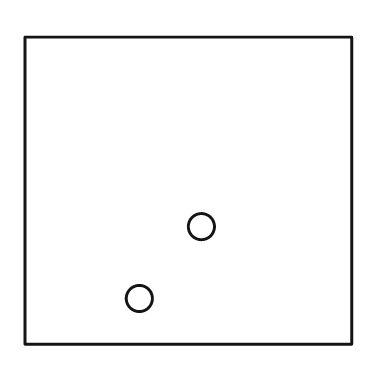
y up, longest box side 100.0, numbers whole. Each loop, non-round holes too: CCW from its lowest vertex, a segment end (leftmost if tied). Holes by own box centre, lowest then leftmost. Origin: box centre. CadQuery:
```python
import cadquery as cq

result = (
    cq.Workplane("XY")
    .moveTo(-50.0, -47.0)
    .lineTo(50.0, -47.0)
    .lineTo(50.0, 47.0)
    .lineTo(-50.0, 47.0)
    .close()
    .moveTo(-15.0, -33.0)
    .circle(4.0)
    .moveTo(4.0, -11.0)
    .circle(4.0)
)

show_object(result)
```